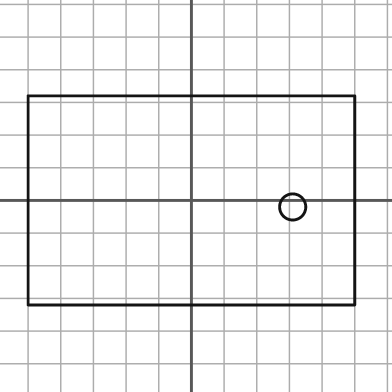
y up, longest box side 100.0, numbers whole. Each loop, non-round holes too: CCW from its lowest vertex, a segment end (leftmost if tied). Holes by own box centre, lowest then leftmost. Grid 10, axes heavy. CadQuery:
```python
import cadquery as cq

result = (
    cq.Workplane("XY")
    .moveTo(-50.0, -32.0)
    .lineTo(50.0, -32.0)
    .lineTo(50.0, 32.0)
    .lineTo(-50.0, 32.0)
    .close()
    .moveTo(31.0, -2.0)
    .circle(4.0)
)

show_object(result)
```